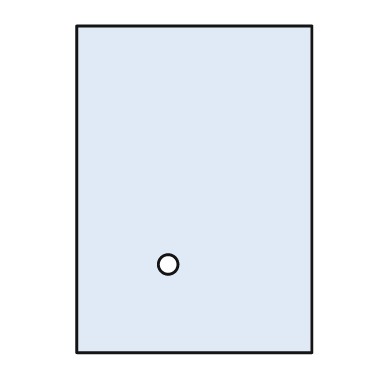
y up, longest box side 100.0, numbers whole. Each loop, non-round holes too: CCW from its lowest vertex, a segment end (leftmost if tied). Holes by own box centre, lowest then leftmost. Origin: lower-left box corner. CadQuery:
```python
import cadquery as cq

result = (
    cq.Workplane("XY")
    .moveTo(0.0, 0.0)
    .lineTo(72.0, 0.0)
    .lineTo(72.0, 100.0)
    .lineTo(0.0, 100.0)
    .close()
    .moveTo(28.0, 27.0)
    .circle(3.0)
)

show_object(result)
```